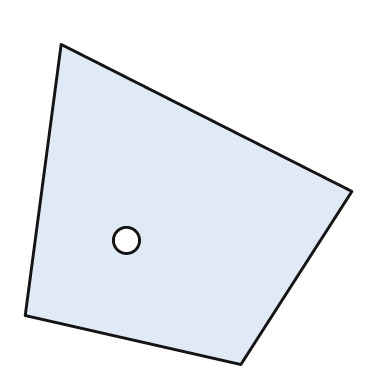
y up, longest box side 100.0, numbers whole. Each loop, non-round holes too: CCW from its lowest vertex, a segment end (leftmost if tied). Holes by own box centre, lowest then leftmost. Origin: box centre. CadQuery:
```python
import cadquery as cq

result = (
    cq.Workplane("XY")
    .moveTo(16.0, -49.0)
    .lineTo(50.0, 4.0)
    .lineTo(-39.0, 49.0)
    .lineTo(-50.0, -34.0)
    .close()
    .moveTo(-19.0, -11.0)
    .circle(4.0)
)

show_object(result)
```